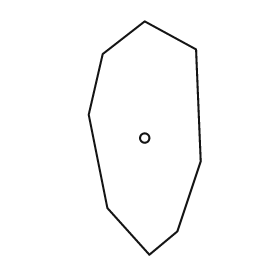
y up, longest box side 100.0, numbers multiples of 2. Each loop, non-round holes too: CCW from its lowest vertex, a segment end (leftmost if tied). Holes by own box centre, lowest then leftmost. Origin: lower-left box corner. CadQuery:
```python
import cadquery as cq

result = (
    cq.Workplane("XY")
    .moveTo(26.0, 0.0)
    .lineTo(38.0, 10.0)
    .lineTo(48.0, 40.0)
    .lineTo(46.0, 88.0)
    .lineTo(24.0, 100.0)
    .lineTo(6.0, 86.0)
    .lineTo(0.0, 60.0)
    .lineTo(8.0, 20.0)
    .close()
    .moveTo(24.0, 50.0)
    .circle(2.0)
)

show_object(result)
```